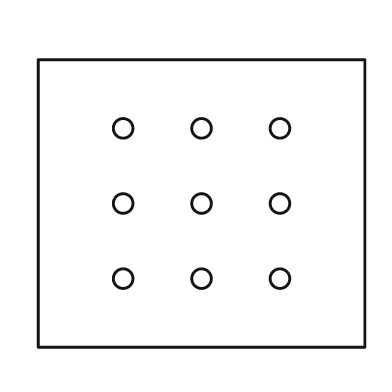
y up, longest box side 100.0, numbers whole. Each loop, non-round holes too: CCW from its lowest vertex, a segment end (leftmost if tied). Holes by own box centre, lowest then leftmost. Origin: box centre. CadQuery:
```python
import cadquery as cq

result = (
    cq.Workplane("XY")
    .moveTo(-50.0, -44.0)
    .lineTo(50.0, -44.0)
    .lineTo(50.0, 44.0)
    .lineTo(-50.0, 44.0)
    .close()
    .moveTo(-24.0, -23.0)
    .circle(3.0)
    .moveTo(0.0, -23.0)
    .circle(3.0)
    .moveTo(24.0, -23.0)
    .circle(3.0)
    .moveTo(-24.0, 0.0)
    .circle(3.0)
    .moveTo(0.0, 0.0)
    .circle(3.0)
    .moveTo(24.0, 0.0)
    .circle(3.0)
    .moveTo(-24.0, 23.0)
    .circle(3.0)
    .moveTo(0.0, 23.0)
    .circle(3.0)
    .moveTo(24.0, 23.0)
    .circle(3.0)
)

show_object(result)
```